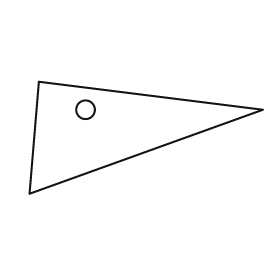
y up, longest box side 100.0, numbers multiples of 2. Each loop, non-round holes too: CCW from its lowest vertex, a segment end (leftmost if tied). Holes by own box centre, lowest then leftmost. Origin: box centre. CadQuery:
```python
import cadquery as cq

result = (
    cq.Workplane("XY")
    .moveTo(-50.0, -24.0)
    .lineTo(50.0, 12.0)
    .lineTo(-46.0, 24.0)
    .close()
    .moveTo(-26.0, 12.0)
    .circle(4.0)
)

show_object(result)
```